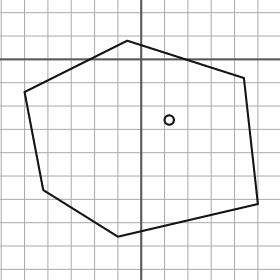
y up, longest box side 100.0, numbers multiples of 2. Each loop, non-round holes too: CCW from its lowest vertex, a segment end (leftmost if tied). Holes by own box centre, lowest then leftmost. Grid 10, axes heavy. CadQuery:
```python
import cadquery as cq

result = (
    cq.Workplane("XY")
    .moveTo(-10.0, -76.0)
    .lineTo(50.0, -62.0)
    .lineTo(44.0, -8.0)
    .lineTo(-6.0, 8.0)
    .lineTo(-50.0, -14.0)
    .lineTo(-42.0, -56.0)
    .close()
    .moveTo(12.0, -26.0)
    .circle(2.0)
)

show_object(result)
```